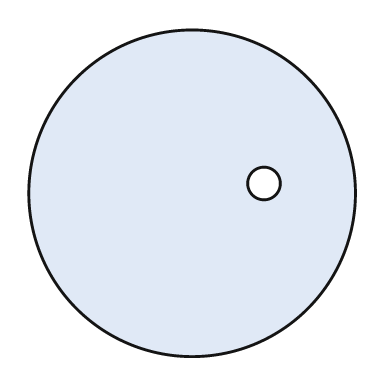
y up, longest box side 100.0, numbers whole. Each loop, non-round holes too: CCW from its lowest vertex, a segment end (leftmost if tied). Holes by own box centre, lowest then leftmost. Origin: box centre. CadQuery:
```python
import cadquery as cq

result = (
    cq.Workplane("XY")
    .moveTo(0.0, 0.0)
    .circle(50.0)
    .moveTo(22.0, 3.0)
    .circle(5.0)
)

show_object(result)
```